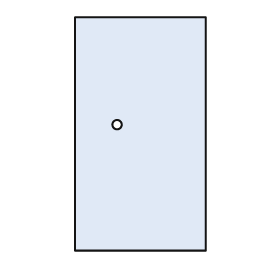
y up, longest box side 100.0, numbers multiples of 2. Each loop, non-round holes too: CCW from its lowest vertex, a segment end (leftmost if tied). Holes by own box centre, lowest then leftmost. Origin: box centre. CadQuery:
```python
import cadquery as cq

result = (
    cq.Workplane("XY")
    .moveTo(-28.0, -50.0)
    .lineTo(28.0, -50.0)
    .lineTo(28.0, 50.0)
    .lineTo(-28.0, 50.0)
    .close()
    .moveTo(-10.0, 4.0)
    .circle(2.0)
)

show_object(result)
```